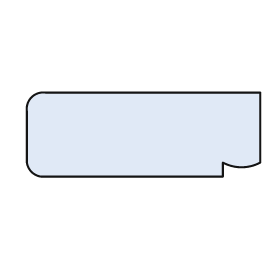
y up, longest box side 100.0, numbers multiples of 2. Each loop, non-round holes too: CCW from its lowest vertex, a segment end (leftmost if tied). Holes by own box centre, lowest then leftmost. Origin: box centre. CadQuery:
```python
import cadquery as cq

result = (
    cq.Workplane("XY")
    .moveTo(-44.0, -18.0)
    .lineTo(34.0, -18.0)
    .lineTo(34.0, -12.0)
    .threePointArc((42.0, -14.0), (50.0, -12.0))
    .lineTo(50.0, 18.0)
    .lineTo(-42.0, 18.0)
    .threePointArc((-48.0, 16.0), (-50.0, 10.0))
    .lineTo(-50.0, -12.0)
    .threePointArc((-48.0, -16.0), (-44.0, -18.0))
    .close()
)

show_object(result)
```